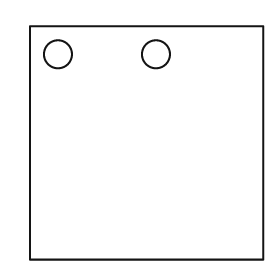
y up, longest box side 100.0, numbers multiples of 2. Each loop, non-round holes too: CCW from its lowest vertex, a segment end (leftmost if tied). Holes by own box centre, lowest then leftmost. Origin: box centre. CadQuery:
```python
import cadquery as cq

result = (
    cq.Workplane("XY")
    .moveTo(-50.0, -50.0)
    .lineTo(50.0, -50.0)
    .lineTo(50.0, 50.0)
    .lineTo(-50.0, 50.0)
    .close()
    .moveTo(-38.0, 38.0)
    .circle(6.0)
    .moveTo(4.0, 38.0)
    .circle(6.0)
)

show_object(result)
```